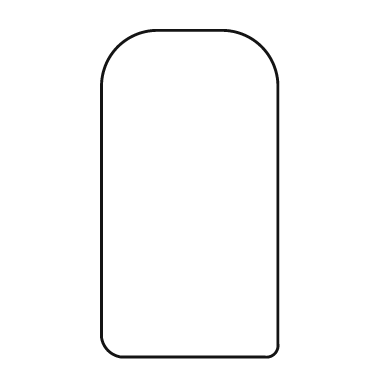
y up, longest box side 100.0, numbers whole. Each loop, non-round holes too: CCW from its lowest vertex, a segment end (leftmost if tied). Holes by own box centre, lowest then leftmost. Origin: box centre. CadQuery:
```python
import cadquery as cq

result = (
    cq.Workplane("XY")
    .moveTo(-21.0, -50.0)
    .lineTo(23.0, -50.0)
    .threePointArc((26.0, -49.0), (27.0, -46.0))
    .lineTo(27.0, 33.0)
    .threePointArc((22.0, 45.0), (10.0, 50.0))
    .lineTo(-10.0, 50.0)
    .threePointArc((-22.0, 45.0), (-27.0, 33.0))
    .lineTo(-27.0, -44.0)
    .threePointArc((-25.0, -48.0), (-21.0, -50.0))
    .close()
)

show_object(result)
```